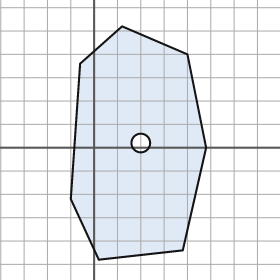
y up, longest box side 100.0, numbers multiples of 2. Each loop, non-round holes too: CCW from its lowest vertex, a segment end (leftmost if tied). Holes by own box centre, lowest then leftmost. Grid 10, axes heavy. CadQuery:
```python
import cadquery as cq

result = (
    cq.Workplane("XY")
    .moveTo(2.0, -48.0)
    .lineTo(38.0, -44.0)
    .lineTo(48.0, 0.0)
    .lineTo(40.0, 40.0)
    .lineTo(12.0, 52.0)
    .lineTo(-6.0, 36.0)
    .lineTo(-10.0, -22.0)
    .close()
    .moveTo(20.0, 2.0)
    .circle(4.0)
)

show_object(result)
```